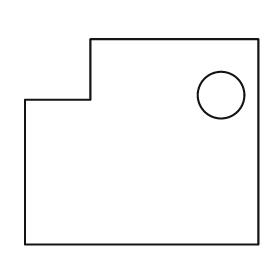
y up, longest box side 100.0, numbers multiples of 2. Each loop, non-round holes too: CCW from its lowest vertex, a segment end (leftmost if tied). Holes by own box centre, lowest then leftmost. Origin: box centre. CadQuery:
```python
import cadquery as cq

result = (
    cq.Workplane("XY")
    .moveTo(-50.0, -44.0)
    .lineTo(50.0, -44.0)
    .lineTo(50.0, 44.0)
    .lineTo(-22.0, 44.0)
    .lineTo(-22.0, 18.0)
    .lineTo(-50.0, 18.0)
    .close()
    .moveTo(34.0, 20.0)
    .circle(10.0)
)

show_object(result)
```